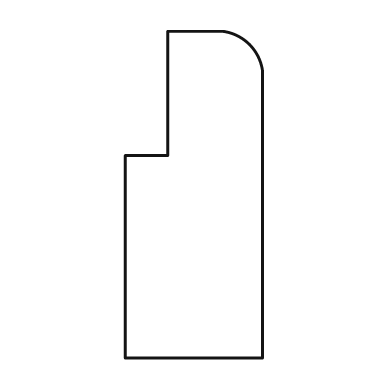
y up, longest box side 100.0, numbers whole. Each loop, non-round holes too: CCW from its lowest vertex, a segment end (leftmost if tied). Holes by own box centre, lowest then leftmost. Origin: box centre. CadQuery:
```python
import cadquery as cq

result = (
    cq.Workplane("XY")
    .moveTo(-21.0, -50.0)
    .lineTo(21.0, -50.0)
    .lineTo(21.0, 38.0)
    .threePointArc((17.0, 46.0), (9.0, 50.0))
    .lineTo(-8.0, 50.0)
    .lineTo(-8.0, 12.0)
    .lineTo(-21.0, 12.0)
    .close()
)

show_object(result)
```